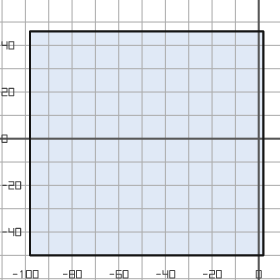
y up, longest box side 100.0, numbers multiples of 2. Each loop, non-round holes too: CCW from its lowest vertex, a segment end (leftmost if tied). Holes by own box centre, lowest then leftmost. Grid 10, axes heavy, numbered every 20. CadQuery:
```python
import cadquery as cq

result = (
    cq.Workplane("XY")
    .moveTo(-98.0, -50.0)
    .lineTo(2.0, -50.0)
    .lineTo(2.0, 46.0)
    .lineTo(-98.0, 46.0)
    .close()
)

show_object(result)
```